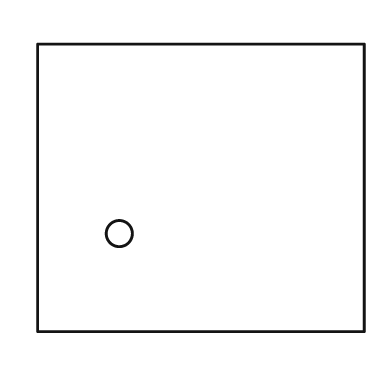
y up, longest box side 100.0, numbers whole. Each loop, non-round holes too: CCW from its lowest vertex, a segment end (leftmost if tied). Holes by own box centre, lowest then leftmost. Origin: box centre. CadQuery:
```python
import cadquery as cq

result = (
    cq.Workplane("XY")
    .moveTo(-50.0, -44.0)
    .lineTo(50.0, -44.0)
    .lineTo(50.0, 44.0)
    .lineTo(-50.0, 44.0)
    .close()
    .moveTo(-25.0, -14.0)
    .circle(4.0)
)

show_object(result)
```